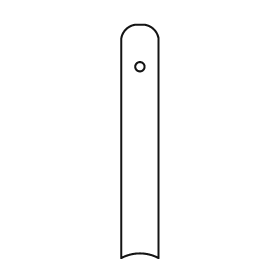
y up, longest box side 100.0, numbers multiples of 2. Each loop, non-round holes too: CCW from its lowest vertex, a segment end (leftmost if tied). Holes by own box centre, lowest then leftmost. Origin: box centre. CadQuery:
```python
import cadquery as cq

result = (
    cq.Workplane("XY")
    .moveTo(-8.0, -50.0)
    .threePointArc((0.0, -48.0), (8.0, -50.0))
    .lineTo(8.0, 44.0)
    .threePointArc((6.0, 48.0), (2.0, 50.0))
    .lineTo(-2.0, 50.0)
    .threePointArc((-6.0, 48.0), (-8.0, 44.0))
    .close()
    .moveTo(0.0, 32.0)
    .circle(2.0)
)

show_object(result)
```